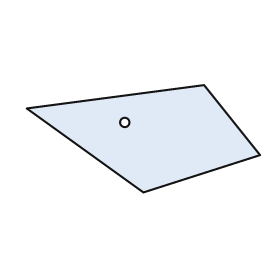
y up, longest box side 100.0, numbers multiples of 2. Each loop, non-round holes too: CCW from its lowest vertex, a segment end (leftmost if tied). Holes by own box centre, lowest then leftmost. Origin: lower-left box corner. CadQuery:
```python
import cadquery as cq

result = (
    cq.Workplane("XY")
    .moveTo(50.0, 0.0)
    .lineTo(100.0, 16.0)
    .lineTo(76.0, 46.0)
    .lineTo(0.0, 36.0)
    .close()
    .moveTo(42.0, 30.0)
    .circle(2.0)
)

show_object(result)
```